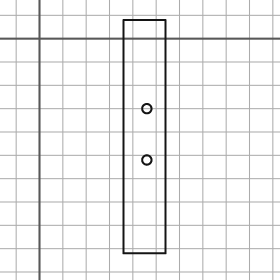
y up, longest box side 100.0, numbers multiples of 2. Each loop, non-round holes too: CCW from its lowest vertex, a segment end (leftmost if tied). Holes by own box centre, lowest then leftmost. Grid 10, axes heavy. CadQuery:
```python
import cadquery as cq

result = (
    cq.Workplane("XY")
    .moveTo(36.0, -92.0)
    .lineTo(54.0, -92.0)
    .lineTo(54.0, 8.0)
    .lineTo(36.0, 8.0)
    .close()
    .moveTo(46.0, -52.0)
    .circle(2.0)
    .moveTo(46.0, -30.0)
    .circle(2.0)
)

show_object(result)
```